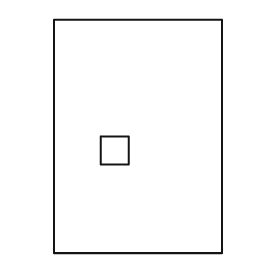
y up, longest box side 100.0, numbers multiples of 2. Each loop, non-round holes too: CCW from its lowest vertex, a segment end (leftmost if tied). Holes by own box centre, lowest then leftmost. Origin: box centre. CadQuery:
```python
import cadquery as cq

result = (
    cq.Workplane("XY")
    .moveTo(-36.0, -50.0)
    .lineTo(36.0, -50.0)
    .lineTo(36.0, 50.0)
    .lineTo(-36.0, 50.0)
    .close()
    .moveTo(-16.0, -12.0)
    .lineTo(-4.0, -12.0)
    .lineTo(-4.0, 0.0)
    .lineTo(-16.0, 0.0)
    .close()
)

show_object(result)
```